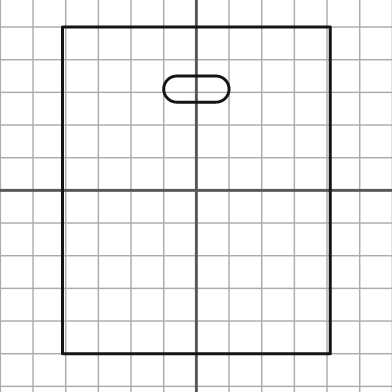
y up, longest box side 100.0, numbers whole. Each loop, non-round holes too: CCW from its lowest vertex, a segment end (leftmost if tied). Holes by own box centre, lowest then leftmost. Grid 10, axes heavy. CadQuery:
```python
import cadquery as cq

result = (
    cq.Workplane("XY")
    .moveTo(-41.0, -50.0)
    .lineTo(41.0, -50.0)
    .lineTo(41.0, 50.0)
    .lineTo(-41.0, 50.0)
    .close()
    .moveTo(-6.0, 27.0)
    .lineTo(6.0, 27.0)
    .threePointArc((10.0, 31.0), (6.0, 35.0))
    .lineTo(-6.0, 35.0)
    .threePointArc((-10.0, 31.0), (-6.0, 27.0))
    .close()
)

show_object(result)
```